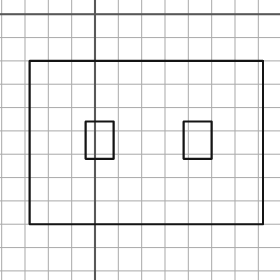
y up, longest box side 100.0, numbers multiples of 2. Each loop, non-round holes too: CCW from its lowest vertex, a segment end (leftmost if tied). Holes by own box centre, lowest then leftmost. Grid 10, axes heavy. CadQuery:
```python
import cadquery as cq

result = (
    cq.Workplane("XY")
    .moveTo(-28.0, -90.0)
    .lineTo(72.0, -90.0)
    .lineTo(72.0, -20.0)
    .lineTo(-28.0, -20.0)
    .close()
    .moveTo(-4.0, -62.0)
    .lineTo(8.0, -62.0)
    .lineTo(8.0, -46.0)
    .lineTo(-4.0, -46.0)
    .close()
    .moveTo(38.0, -62.0)
    .lineTo(50.0, -62.0)
    .lineTo(50.0, -46.0)
    .lineTo(38.0, -46.0)
    .close()
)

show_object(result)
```